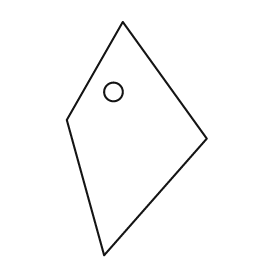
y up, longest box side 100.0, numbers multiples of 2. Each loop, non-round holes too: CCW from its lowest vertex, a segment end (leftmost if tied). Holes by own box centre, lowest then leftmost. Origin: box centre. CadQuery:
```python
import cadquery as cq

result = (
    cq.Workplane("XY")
    .moveTo(-14.0, -50.0)
    .lineTo(30.0, 0.0)
    .lineTo(-6.0, 50.0)
    .lineTo(-30.0, 8.0)
    .close()
    .moveTo(-10.0, 20.0)
    .circle(4.0)
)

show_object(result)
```